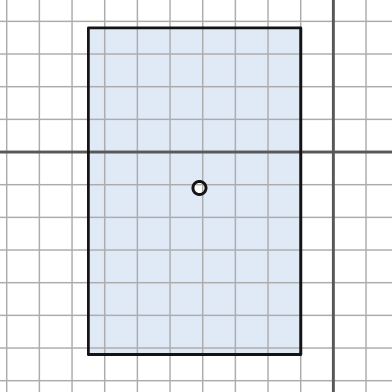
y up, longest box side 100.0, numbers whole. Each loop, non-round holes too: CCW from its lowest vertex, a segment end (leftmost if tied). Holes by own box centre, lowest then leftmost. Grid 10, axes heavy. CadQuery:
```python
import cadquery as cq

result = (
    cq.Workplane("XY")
    .moveTo(-75.0, -62.0)
    .lineTo(-10.0, -62.0)
    .lineTo(-10.0, 38.0)
    .lineTo(-75.0, 38.0)
    .close()
    .moveTo(-41.0, -11.0)
    .circle(2.0)
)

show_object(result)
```